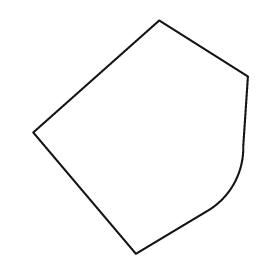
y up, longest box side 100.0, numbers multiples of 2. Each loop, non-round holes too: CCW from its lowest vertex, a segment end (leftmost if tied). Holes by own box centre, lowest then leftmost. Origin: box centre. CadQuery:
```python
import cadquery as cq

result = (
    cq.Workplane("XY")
    .moveTo(-2.0, -50.0)
    .lineTo(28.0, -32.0)
    .threePointArc((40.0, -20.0), (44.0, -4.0))
    .lineTo(46.0, 26.0)
    .lineTo(8.0, 50.0)
    .lineTo(-46.0, 2.0)
    .close()
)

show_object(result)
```